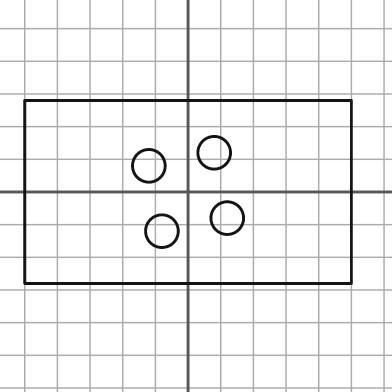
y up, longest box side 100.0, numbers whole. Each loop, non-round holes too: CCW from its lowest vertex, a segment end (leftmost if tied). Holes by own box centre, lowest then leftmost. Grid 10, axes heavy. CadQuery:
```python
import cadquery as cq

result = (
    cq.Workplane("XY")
    .moveTo(-50.0, -28.0)
    .lineTo(50.0, -28.0)
    .lineTo(50.0, 28.0)
    .lineTo(-50.0, 28.0)
    .close()
    .moveTo(-8.0, -12.0)
    .circle(5.0)
    .moveTo(12.0, -8.0)
    .circle(5.0)
    .moveTo(-12.0, 8.0)
    .circle(5.0)
    .moveTo(8.0, 12.0)
    .circle(5.0)
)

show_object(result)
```